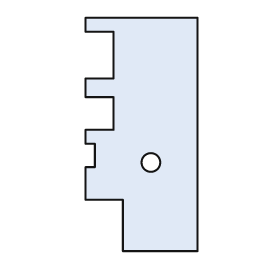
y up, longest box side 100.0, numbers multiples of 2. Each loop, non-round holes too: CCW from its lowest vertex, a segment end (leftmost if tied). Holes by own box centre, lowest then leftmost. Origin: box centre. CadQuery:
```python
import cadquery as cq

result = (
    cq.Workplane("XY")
    .moveTo(-8.0, -50.0)
    .lineTo(24.0, -50.0)
    .lineTo(24.0, 50.0)
    .lineTo(-24.0, 50.0)
    .lineTo(-24.0, 44.0)
    .lineTo(-12.0, 44.0)
    .lineTo(-12.0, 24.0)
    .lineTo(-24.0, 24.0)
    .lineTo(-24.0, 16.0)
    .lineTo(-12.0, 16.0)
    .lineTo(-12.0, 2.0)
    .lineTo(-24.0, 2.0)
    .lineTo(-24.0, -4.0)
    .lineTo(-20.0, -4.0)
    .lineTo(-20.0, -14.0)
    .lineTo(-24.0, -14.0)
    .lineTo(-24.0, -28.0)
    .lineTo(-8.0, -28.0)
    .close()
    .moveTo(4.0, -12.0)
    .circle(4.0)
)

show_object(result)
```